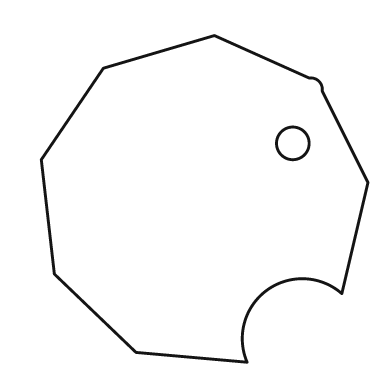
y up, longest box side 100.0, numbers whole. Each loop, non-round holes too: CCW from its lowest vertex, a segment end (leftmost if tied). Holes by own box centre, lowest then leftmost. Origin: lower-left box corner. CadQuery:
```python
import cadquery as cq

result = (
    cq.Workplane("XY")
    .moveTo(63.0, 0.0)
    .threePointArc((69.0, 22.0), (92.0, 21.0))
    .lineTo(100.0, 55.0)
    .lineTo(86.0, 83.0)
    .threePointArc((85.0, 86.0), (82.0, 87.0))
    .lineTo(53.0, 100.0)
    .lineTo(19.0, 90.0)
    .lineTo(0.0, 62.0)
    .lineTo(4.0, 27.0)
    .lineTo(29.0, 3.0)
    .close()
    .moveTo(77.0, 67.0)
    .circle(5.0)
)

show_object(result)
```